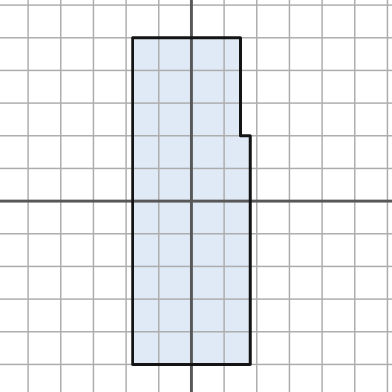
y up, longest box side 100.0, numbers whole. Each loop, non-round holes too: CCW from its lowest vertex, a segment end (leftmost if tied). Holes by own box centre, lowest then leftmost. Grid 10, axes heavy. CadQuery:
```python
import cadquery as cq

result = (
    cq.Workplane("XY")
    .moveTo(-18.0, -50.0)
    .lineTo(18.0, -50.0)
    .lineTo(18.0, 20.0)
    .lineTo(15.0, 20.0)
    .lineTo(15.0, 50.0)
    .lineTo(-18.0, 50.0)
    .close()
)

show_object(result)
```